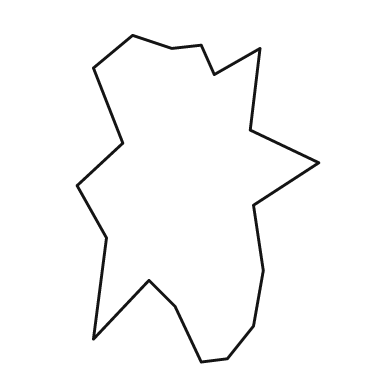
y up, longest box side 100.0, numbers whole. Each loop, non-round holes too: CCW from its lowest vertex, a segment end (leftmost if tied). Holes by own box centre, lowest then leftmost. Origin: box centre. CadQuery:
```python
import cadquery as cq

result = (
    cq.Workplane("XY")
    .moveTo(1.0, -50.0)
    .lineTo(9.0, -49.0)
    .lineTo(17.0, -39.0)
    .lineTo(20.0, -22.0)
    .lineTo(17.0, -2.0)
    .lineTo(37.0, 11.0)
    .lineTo(16.0, 21.0)
    .lineTo(19.0, 46.0)
    .lineTo(5.0, 38.0)
    .lineTo(1.0, 47.0)
    .lineTo(-8.0, 46.0)
    .lineTo(-20.0, 50.0)
    .lineTo(-32.0, 40.0)
    .lineTo(-23.0, 17.0)
    .lineTo(-37.0, 4.0)
    .lineTo(-28.0, -12.0)
    .lineTo(-32.0, -43.0)
    .lineTo(-15.0, -25.0)
    .lineTo(-7.0, -33.0)
    .close()
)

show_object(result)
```